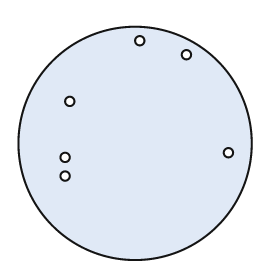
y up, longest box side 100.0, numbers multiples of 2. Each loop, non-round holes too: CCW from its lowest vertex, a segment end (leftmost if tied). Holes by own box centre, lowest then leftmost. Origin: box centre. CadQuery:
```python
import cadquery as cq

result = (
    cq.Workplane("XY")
    .moveTo(0.0, 0.0)
    .circle(50.0)
    .moveTo(-30.0, -14.0)
    .circle(2.0)
    .moveTo(-30.0, -6.0)
    .circle(2.0)
    .moveTo(40.0, -4.0)
    .circle(2.0)
    .moveTo(-28.0, 18.0)
    .circle(2.0)
    .moveTo(22.0, 38.0)
    .circle(2.0)
    .moveTo(2.0, 44.0)
    .circle(2.0)
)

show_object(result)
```